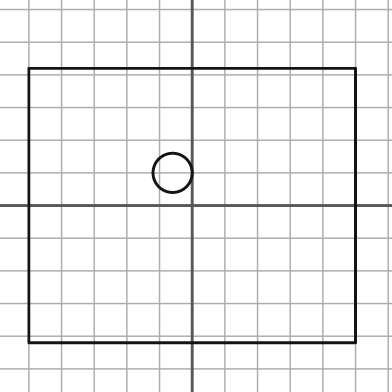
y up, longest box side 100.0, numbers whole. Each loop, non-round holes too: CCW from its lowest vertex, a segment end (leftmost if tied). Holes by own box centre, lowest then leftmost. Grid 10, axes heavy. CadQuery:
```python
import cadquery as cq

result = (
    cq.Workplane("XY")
    .moveTo(-50.0, -42.0)
    .lineTo(50.0, -42.0)
    .lineTo(50.0, 42.0)
    .lineTo(-50.0, 42.0)
    .close()
    .moveTo(-6.0, 10.0)
    .circle(6.0)
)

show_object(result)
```